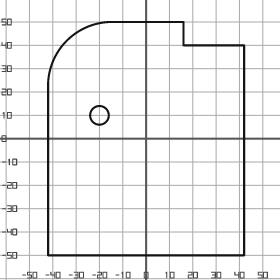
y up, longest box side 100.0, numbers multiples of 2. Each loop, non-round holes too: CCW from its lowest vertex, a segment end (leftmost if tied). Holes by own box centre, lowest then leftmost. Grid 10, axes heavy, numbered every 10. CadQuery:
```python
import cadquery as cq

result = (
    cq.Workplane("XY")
    .moveTo(-42.0, -50.0)
    .lineTo(42.0, -50.0)
    .lineTo(42.0, 40.0)
    .lineTo(16.0, 40.0)
    .lineTo(16.0, 50.0)
    .lineTo(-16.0, 50.0)
    .threePointArc((-34.0, 42.0), (-42.0, 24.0))
    .close()
    .moveTo(-20.0, 10.0)
    .circle(4.0)
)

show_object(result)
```